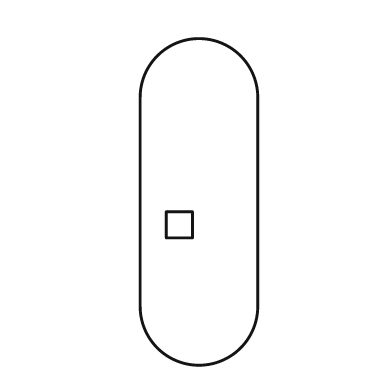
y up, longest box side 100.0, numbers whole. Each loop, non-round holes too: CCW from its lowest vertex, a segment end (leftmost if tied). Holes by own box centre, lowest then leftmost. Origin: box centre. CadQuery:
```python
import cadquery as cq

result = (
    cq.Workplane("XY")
    .moveTo(-18.0, -32.0)
    .threePointArc((0.0, -50.0), (18.0, -32.0))
    .lineTo(18.0, 32.0)
    .threePointArc((0.0, 50.0), (-18.0, 32.0))
    .close()
    .moveTo(-10.0, -11.0)
    .lineTo(-2.0, -11.0)
    .lineTo(-2.0, -3.0)
    .lineTo(-10.0, -3.0)
    .close()
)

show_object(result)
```